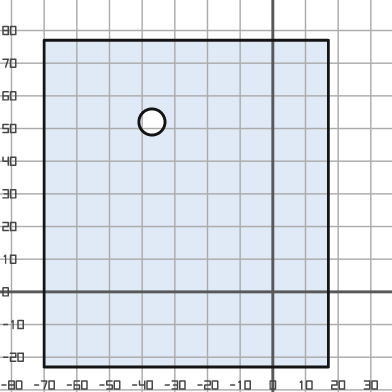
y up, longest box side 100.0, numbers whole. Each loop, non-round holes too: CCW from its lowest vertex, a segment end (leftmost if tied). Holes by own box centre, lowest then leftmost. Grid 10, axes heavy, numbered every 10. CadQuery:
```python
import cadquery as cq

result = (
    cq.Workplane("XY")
    .moveTo(-70.0, -23.0)
    .lineTo(17.0, -23.0)
    .lineTo(17.0, 77.0)
    .lineTo(-70.0, 77.0)
    .close()
    .moveTo(-37.0, 52.0)
    .circle(4.0)
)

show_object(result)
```